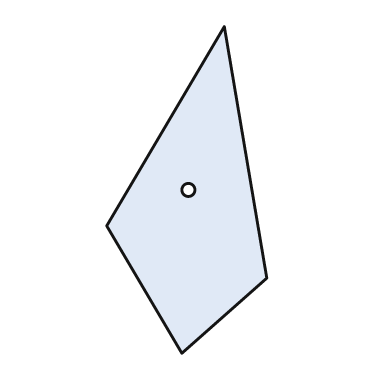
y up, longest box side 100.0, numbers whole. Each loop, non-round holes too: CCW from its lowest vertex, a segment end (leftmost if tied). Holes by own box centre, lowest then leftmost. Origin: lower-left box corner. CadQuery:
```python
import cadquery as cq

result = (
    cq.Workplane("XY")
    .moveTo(23.0, 0.0)
    .lineTo(49.0, 23.0)
    .lineTo(36.0, 100.0)
    .lineTo(0.0, 39.0)
    .close()
    .moveTo(25.0, 50.0)
    .circle(2.0)
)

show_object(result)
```